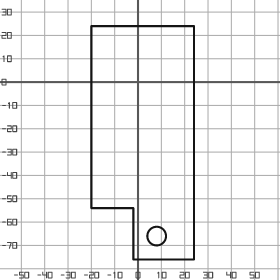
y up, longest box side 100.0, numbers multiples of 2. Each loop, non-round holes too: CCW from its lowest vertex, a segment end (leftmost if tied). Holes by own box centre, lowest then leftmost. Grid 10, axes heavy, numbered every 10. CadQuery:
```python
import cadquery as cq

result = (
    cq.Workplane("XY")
    .moveTo(-2.0, -76.0)
    .lineTo(24.0, -76.0)
    .lineTo(24.0, 24.0)
    .lineTo(-20.0, 24.0)
    .lineTo(-20.0, -54.0)
    .lineTo(-2.0, -54.0)
    .close()
    .moveTo(8.0, -66.0)
    .circle(4.0)
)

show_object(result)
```